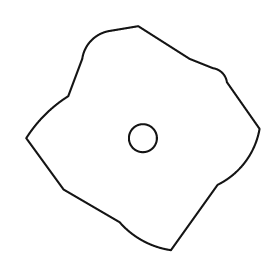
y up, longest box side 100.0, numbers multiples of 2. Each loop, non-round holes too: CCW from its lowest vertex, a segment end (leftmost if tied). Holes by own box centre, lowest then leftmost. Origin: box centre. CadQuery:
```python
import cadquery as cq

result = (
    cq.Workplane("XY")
    .moveTo(12.0, -48.0)
    .lineTo(32.0, -20.0)
    .threePointArc((44.0, -10.0), (50.0, 4.0))
    .lineTo(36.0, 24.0)
    .threePointArc((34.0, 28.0), (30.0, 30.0))
    .lineTo(20.0, 34.0)
    .lineTo(-2.0, 48.0)
    .lineTo(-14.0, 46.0)
    .threePointArc((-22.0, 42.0), (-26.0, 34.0))
    .lineTo(-32.0, 18.0)
    .threePointArc((-42.0, 10.0), (-50.0, 0.0))
    .lineTo(-34.0, -22.0)
    .lineTo(-10.0, -36.0)
    .threePointArc((0.0, -44.0), (12.0, -48.0))
    .close()
    .moveTo(0.0, 0.0)
    .circle(6.0)
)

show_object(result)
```